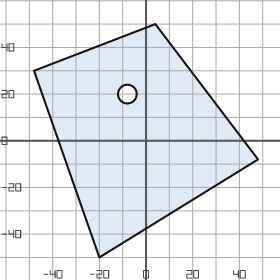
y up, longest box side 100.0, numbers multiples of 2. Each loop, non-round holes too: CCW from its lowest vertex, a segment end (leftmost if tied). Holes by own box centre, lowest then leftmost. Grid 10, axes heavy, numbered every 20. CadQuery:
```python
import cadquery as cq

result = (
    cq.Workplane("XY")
    .moveTo(-20.0, -50.0)
    .lineTo(48.0, -8.0)
    .lineTo(4.0, 50.0)
    .lineTo(-48.0, 30.0)
    .close()
    .moveTo(-8.0, 20.0)
    .circle(4.0)
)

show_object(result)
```